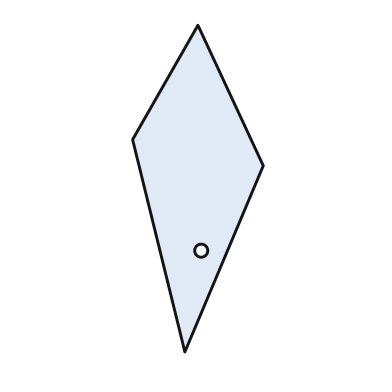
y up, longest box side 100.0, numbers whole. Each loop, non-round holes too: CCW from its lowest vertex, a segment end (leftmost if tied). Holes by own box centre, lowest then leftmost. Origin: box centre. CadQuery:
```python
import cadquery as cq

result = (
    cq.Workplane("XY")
    .moveTo(-4.0, -50.0)
    .lineTo(20.0, 7.0)
    .lineTo(0.0, 50.0)
    .lineTo(-20.0, 15.0)
    .close()
    .moveTo(1.0, -19.0)
    .circle(2.0)
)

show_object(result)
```